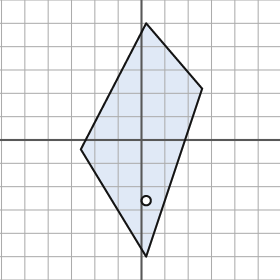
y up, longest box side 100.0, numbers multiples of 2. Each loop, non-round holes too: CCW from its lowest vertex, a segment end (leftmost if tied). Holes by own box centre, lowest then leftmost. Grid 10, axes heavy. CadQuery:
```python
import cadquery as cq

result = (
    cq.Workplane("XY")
    .moveTo(2.0, -50.0)
    .lineTo(26.0, 22.0)
    .lineTo(2.0, 50.0)
    .lineTo(-26.0, -4.0)
    .close()
    .moveTo(2.0, -26.0)
    .circle(2.0)
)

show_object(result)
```